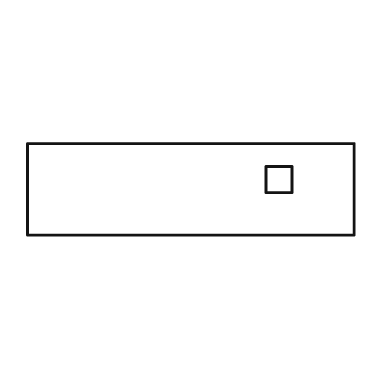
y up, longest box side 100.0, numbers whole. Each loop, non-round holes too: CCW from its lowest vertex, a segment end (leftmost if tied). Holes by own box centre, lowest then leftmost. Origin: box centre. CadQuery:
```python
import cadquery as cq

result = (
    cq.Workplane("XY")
    .moveTo(-50.0, -14.0)
    .lineTo(50.0, -14.0)
    .lineTo(50.0, 14.0)
    .lineTo(-50.0, 14.0)
    .close()
    .moveTo(23.0, -1.0)
    .lineTo(31.0, -1.0)
    .lineTo(31.0, 7.0)
    .lineTo(23.0, 7.0)
    .close()
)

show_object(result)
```